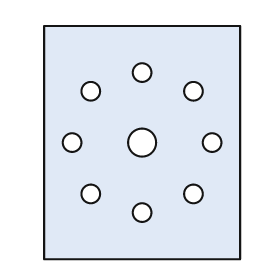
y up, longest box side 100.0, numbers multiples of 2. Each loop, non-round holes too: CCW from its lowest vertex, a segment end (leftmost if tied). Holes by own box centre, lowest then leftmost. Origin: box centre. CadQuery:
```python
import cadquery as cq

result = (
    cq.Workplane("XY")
    .moveTo(-42.0, -50.0)
    .lineTo(42.0, -50.0)
    .lineTo(42.0, 50.0)
    .lineTo(-42.0, 50.0)
    .close()
    .moveTo(0.0, -30.0)
    .circle(4.0)
    .moveTo(-22.0, -22.0)
    .circle(4.0)
    .moveTo(22.0, -22.0)
    .circle(4.0)
    .moveTo(-30.0, 0.0)
    .circle(4.0)
    .moveTo(0.0, 0.0)
    .circle(6.0)
    .moveTo(30.0, 0.0)
    .circle(4.0)
    .moveTo(-22.0, 22.0)
    .circle(4.0)
    .moveTo(22.0, 22.0)
    .circle(4.0)
    .moveTo(0.0, 30.0)
    .circle(4.0)
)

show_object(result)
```